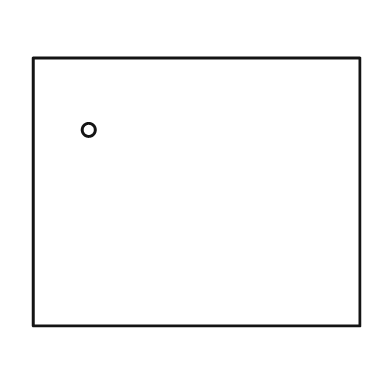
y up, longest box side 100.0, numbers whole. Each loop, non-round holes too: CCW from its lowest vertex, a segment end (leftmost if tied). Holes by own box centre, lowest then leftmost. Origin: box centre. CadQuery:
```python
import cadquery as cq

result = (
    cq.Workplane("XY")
    .moveTo(-50.0, -41.0)
    .lineTo(50.0, -41.0)
    .lineTo(50.0, 41.0)
    .lineTo(-50.0, 41.0)
    .close()
    .moveTo(-33.0, 19.0)
    .circle(2.0)
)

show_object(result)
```